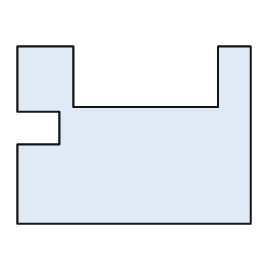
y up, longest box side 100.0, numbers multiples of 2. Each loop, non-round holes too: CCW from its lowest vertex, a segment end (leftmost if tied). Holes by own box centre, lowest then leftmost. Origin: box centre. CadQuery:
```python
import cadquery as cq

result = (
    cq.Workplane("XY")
    .moveTo(-50.0, -38.0)
    .lineTo(50.0, -38.0)
    .lineTo(50.0, 38.0)
    .lineTo(36.0, 38.0)
    .lineTo(36.0, 12.0)
    .lineTo(-26.0, 12.0)
    .lineTo(-26.0, 38.0)
    .lineTo(-50.0, 38.0)
    .lineTo(-50.0, 10.0)
    .lineTo(-32.0, 10.0)
    .lineTo(-32.0, -4.0)
    .lineTo(-50.0, -4.0)
    .close()
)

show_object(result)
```